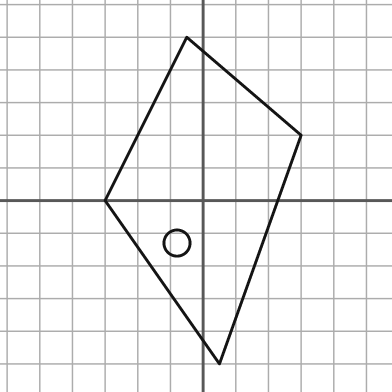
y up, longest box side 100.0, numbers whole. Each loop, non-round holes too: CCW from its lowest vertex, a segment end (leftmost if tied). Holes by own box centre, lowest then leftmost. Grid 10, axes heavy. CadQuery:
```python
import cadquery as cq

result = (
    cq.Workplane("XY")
    .moveTo(5.0, -50.0)
    .lineTo(30.0, 20.0)
    .lineTo(-5.0, 50.0)
    .lineTo(-30.0, 0.0)
    .close()
    .moveTo(-8.0, -13.0)
    .circle(4.0)
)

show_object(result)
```